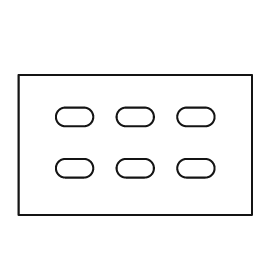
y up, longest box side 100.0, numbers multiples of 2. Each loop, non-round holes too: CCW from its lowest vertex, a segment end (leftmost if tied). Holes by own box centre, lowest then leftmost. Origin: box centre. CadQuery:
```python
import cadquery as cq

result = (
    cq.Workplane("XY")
    .moveTo(-50.0, -30.0)
    .lineTo(50.0, -30.0)
    .lineTo(50.0, 30.0)
    .lineTo(-50.0, 30.0)
    .close()
    .moveTo(-30.0, -14.0)
    .lineTo(-22.0, -14.0)
    .threePointArc((-18.0, -10.0), (-22.0, -6.0))
    .lineTo(-30.0, -6.0)
    .threePointArc((-34.0, -10.0), (-30.0, -14.0))
    .close()
    .moveTo(-4.0, -14.0)
    .lineTo(4.0, -14.0)
    .threePointArc((8.0, -10.0), (4.0, -6.0))
    .lineTo(-4.0, -6.0)
    .threePointArc((-8.0, -10.0), (-4.0, -14.0))
    .close()
    .moveTo(22.0, -14.0)
    .lineTo(30.0, -14.0)
    .threePointArc((34.0, -10.0), (30.0, -6.0))
    .lineTo(22.0, -6.0)
    .threePointArc((18.0, -10.0), (22.0, -14.0))
    .close()
    .moveTo(-30.0, 8.0)
    .lineTo(-22.0, 8.0)
    .threePointArc((-18.0, 12.0), (-22.0, 16.0))
    .lineTo(-30.0, 16.0)
    .threePointArc((-34.0, 12.0), (-30.0, 8.0))
    .close()
    .moveTo(-4.0, 8.0)
    .lineTo(4.0, 8.0)
    .threePointArc((8.0, 12.0), (4.0, 16.0))
    .lineTo(-4.0, 16.0)
    .threePointArc((-8.0, 12.0), (-4.0, 8.0))
    .close()
    .moveTo(22.0, 8.0)
    .lineTo(30.0, 8.0)
    .threePointArc((34.0, 12.0), (30.0, 16.0))
    .lineTo(22.0, 16.0)
    .threePointArc((18.0, 12.0), (22.0, 8.0))
    .close()
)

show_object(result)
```